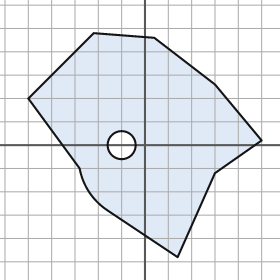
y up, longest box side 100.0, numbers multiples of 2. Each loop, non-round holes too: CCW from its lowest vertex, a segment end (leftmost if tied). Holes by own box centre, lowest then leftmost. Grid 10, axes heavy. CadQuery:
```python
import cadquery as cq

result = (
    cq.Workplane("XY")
    .moveTo(14.0, -48.0)
    .lineTo(30.0, -12.0)
    .lineTo(50.0, 2.0)
    .lineTo(30.0, 26.0)
    .lineTo(4.0, 46.0)
    .lineTo(-22.0, 48.0)
    .lineTo(-50.0, 20.0)
    .lineTo(-28.0, -10.0)
    .threePointArc((-24.0, -20.0), (-16.0, -28.0))
    .close()
    .moveTo(-10.0, 0.0)
    .circle(6.0)
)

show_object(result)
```